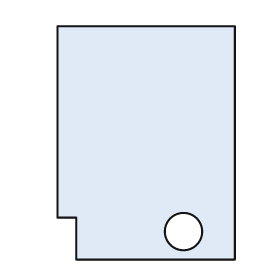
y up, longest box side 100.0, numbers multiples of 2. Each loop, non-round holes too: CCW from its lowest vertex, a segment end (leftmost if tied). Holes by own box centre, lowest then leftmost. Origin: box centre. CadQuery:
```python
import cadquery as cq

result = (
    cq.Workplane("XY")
    .moveTo(-30.0, -50.0)
    .lineTo(38.0, -50.0)
    .lineTo(38.0, 50.0)
    .lineTo(-38.0, 50.0)
    .lineTo(-38.0, -32.0)
    .lineTo(-30.0, -32.0)
    .close()
    .moveTo(16.0, -38.0)
    .circle(8.0)
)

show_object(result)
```